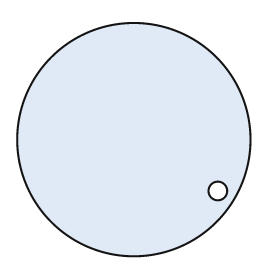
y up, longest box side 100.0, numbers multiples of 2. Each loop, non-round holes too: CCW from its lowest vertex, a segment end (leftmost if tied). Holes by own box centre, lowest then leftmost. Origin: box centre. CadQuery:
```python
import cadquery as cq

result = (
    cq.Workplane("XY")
    .moveTo(0.0, 0.0)
    .circle(50.0)
    .moveTo(36.0, -22.0)
    .circle(4.0)
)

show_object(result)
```